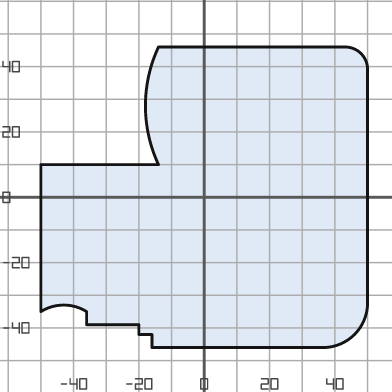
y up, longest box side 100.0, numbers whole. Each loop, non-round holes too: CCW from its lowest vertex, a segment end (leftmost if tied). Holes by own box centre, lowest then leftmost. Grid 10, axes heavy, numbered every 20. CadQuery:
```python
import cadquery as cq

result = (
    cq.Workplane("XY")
    .moveTo(-16.0, -46.0)
    .lineTo(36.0, -46.0)
    .threePointArc((46.0, -42.0), (50.0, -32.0))
    .lineTo(50.0, 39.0)
    .threePointArc((48.0, 44.0), (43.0, 46.0))
    .lineTo(-14.0, 46.0)
    .threePointArc((-18.0, 28.0), (-14.0, 10.0))
    .lineTo(-50.0, 10.0)
    .lineTo(-50.0, -35.0)
    .threePointArc((-43.0, -33.0), (-36.0, -35.0))
    .lineTo(-36.0, -39.0)
    .lineTo(-20.0, -39.0)
    .lineTo(-20.0, -42.0)
    .lineTo(-16.0, -42.0)
    .close()
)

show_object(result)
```